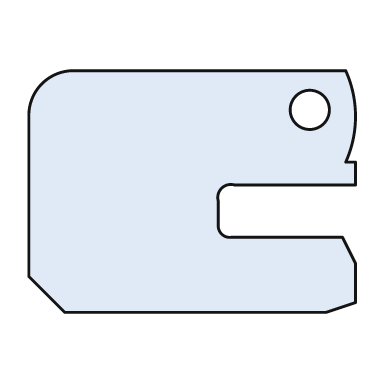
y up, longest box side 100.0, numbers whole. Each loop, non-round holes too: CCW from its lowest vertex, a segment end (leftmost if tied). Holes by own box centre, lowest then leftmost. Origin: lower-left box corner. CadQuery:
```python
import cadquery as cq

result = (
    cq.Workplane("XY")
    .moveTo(11.0, 0.0)
    .lineTo(91.0, 0.0)
    .lineTo(100.0, 3.0)
    .lineTo(100.0, 15.0)
    .lineTo(96.0, 23.0)
    .lineTo(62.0, 23.0)
    .threePointArc((59.0, 24.0), (58.0, 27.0))
    .lineTo(58.0, 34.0)
    .threePointArc((59.0, 38.0), (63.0, 39.0))
    .lineTo(100.0, 39.0)
    .lineTo(100.0, 46.0)
    .lineTo(97.0, 46.0)
    .threePointArc((100.0, 60.0), (97.0, 74.0))
    .lineTo(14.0, 74.0)
    .threePointArc((4.0, 70.0), (0.0, 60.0))
    .lineTo(0.0, 11.0)
    .close()
    .moveTo(86.0, 62.0)
    .circle(6.0)
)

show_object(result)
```